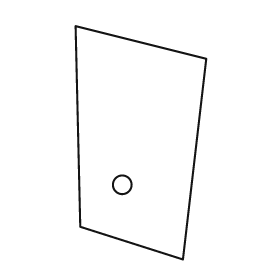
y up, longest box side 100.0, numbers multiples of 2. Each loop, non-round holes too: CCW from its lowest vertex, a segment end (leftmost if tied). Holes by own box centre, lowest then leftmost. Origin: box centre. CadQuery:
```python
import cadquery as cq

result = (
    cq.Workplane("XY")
    .moveTo(18.0, -50.0)
    .lineTo(28.0, 36.0)
    .lineTo(-28.0, 50.0)
    .lineTo(-26.0, -36.0)
    .close()
    .moveTo(-8.0, -18.0)
    .circle(4.0)
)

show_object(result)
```